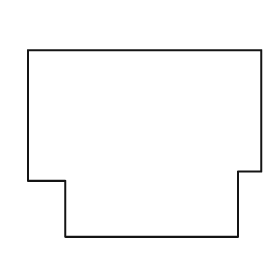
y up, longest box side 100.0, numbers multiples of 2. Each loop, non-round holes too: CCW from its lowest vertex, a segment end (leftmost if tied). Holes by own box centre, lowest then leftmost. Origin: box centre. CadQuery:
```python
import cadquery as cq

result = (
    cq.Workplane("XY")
    .moveTo(-34.0, -40.0)
    .lineTo(40.0, -40.0)
    .lineTo(40.0, -12.0)
    .lineTo(50.0, -12.0)
    .lineTo(50.0, 40.0)
    .lineTo(-50.0, 40.0)
    .lineTo(-50.0, -16.0)
    .lineTo(-34.0, -16.0)
    .close()
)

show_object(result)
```